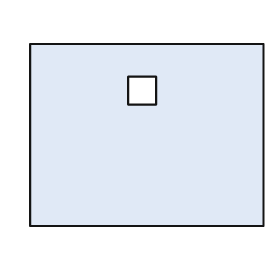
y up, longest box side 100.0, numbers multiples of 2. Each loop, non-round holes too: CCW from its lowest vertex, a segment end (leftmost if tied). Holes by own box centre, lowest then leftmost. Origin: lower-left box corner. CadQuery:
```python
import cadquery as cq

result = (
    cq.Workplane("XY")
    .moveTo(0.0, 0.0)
    .lineTo(100.0, 0.0)
    .lineTo(100.0, 78.0)
    .lineTo(0.0, 78.0)
    .close()
    .moveTo(42.0, 52.0)
    .lineTo(54.0, 52.0)
    .lineTo(54.0, 64.0)
    .lineTo(42.0, 64.0)
    .close()
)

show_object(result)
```